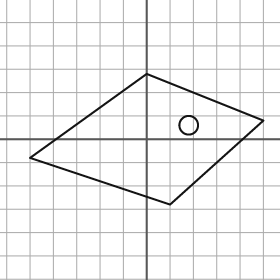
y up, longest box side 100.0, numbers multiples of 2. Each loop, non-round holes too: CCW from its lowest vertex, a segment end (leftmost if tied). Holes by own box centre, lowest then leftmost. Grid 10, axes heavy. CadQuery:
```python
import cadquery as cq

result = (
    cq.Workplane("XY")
    .moveTo(10.0, -28.0)
    .lineTo(50.0, 8.0)
    .lineTo(0.0, 28.0)
    .lineTo(-50.0, -8.0)
    .close()
    .moveTo(18.0, 6.0)
    .circle(4.0)
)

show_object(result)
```